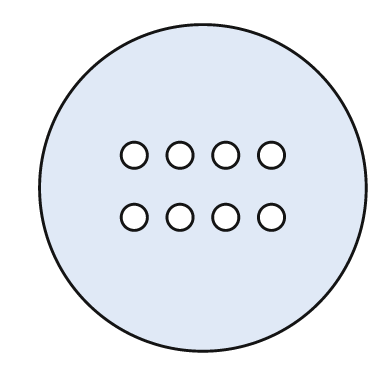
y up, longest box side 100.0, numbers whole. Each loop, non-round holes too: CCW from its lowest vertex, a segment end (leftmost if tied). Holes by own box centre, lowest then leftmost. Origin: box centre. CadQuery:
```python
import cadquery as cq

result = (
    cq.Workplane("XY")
    .moveTo(0.0, 0.0)
    .circle(50.0)
    .moveTo(-21.0, -9.0)
    .circle(4.0)
    .moveTo(-7.0, -9.0)
    .circle(4.0)
    .moveTo(7.0, -9.0)
    .circle(4.0)
    .moveTo(21.0, -9.0)
    .circle(4.0)
    .moveTo(-21.0, 10.0)
    .circle(4.0)
    .moveTo(-7.0, 10.0)
    .circle(4.0)
    .moveTo(7.0, 10.0)
    .circle(4.0)
    .moveTo(21.0, 10.0)
    .circle(4.0)
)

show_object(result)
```